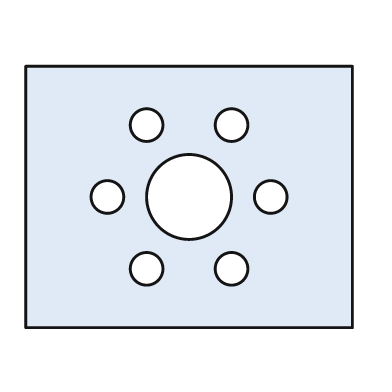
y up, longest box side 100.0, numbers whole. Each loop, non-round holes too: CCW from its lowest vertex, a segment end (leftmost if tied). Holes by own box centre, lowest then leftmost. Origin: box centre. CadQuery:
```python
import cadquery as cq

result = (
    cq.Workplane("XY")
    .moveTo(-50.0, -40.0)
    .lineTo(50.0, -40.0)
    .lineTo(50.0, 40.0)
    .lineTo(-50.0, 40.0)
    .close()
    .moveTo(-13.0, -22.0)
    .circle(5.0)
    .moveTo(13.0, -22.0)
    .circle(5.0)
    .moveTo(-25.0, 0.0)
    .circle(5.0)
    .moveTo(0.0, 0.0)
    .circle(13.0)
    .moveTo(25.0, 0.0)
    .circle(5.0)
    .moveTo(-13.0, 22.0)
    .circle(5.0)
    .moveTo(13.0, 22.0)
    .circle(5.0)
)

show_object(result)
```